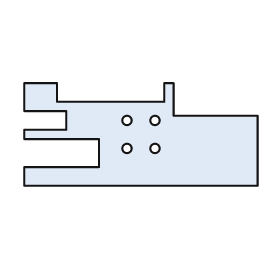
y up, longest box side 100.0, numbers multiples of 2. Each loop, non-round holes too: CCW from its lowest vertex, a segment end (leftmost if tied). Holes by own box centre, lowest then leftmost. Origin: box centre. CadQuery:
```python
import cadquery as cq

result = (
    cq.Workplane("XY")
    .moveTo(-50.0, -22.0)
    .lineTo(50.0, -22.0)
    .lineTo(50.0, 8.0)
    .lineTo(14.0, 8.0)
    .lineTo(14.0, 22.0)
    .lineTo(10.0, 22.0)
    .lineTo(10.0, 14.0)
    .lineTo(-36.0, 14.0)
    .lineTo(-36.0, 22.0)
    .lineTo(-50.0, 22.0)
    .lineTo(-50.0, 10.0)
    .lineTo(-32.0, 10.0)
    .lineTo(-32.0, 2.0)
    .lineTo(-50.0, 2.0)
    .lineTo(-50.0, -2.0)
    .lineTo(-18.0, -2.0)
    .lineTo(-18.0, -14.0)
    .lineTo(-50.0, -14.0)
    .close()
    .moveTo(-6.0, -6.0)
    .circle(2.0)
    .moveTo(6.0, -6.0)
    .circle(2.0)
    .moveTo(-6.0, 6.0)
    .circle(2.0)
    .moveTo(6.0, 6.0)
    .circle(2.0)
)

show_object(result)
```